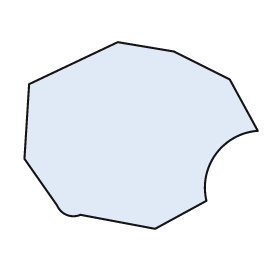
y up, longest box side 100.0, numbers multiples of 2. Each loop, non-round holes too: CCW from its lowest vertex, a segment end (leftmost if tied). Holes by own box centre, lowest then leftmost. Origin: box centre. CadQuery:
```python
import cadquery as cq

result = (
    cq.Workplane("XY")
    .moveTo(6.0, -40.0)
    .lineTo(28.0, -28.0)
    .threePointArc((32.0, -8.0), (50.0, 2.0))
    .lineTo(38.0, 24.0)
    .lineTo(14.0, 36.0)
    .lineTo(-10.0, 40.0)
    .lineTo(-48.0, 22.0)
    .lineTo(-50.0, -10.0)
    .lineTo(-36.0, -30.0)
    .threePointArc((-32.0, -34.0), (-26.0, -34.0))
    .close()
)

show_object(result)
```